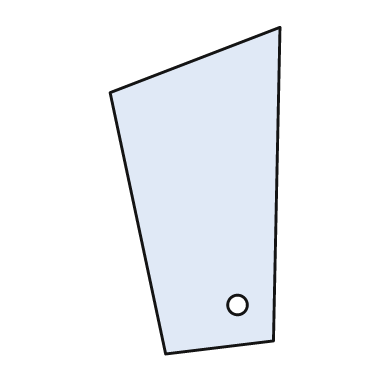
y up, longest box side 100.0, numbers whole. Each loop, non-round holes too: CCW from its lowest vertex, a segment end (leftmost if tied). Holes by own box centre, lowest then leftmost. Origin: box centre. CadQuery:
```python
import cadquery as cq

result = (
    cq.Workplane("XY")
    .moveTo(-9.0, -50.0)
    .lineTo(24.0, -46.0)
    .lineTo(26.0, 50.0)
    .lineTo(-26.0, 30.0)
    .close()
    .moveTo(13.0, -35.0)
    .circle(3.0)
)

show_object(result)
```